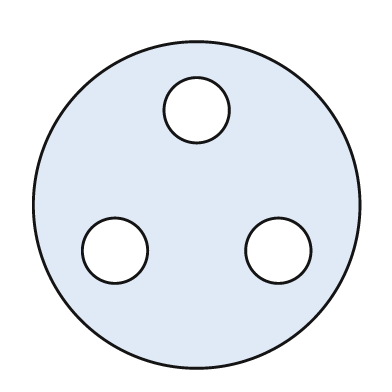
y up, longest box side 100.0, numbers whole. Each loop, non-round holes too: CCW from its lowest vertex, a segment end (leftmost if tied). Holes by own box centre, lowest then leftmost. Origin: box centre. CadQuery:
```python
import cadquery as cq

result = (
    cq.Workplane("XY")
    .moveTo(0.0, 0.0)
    .circle(50.0)
    .moveTo(-25.0, -14.0)
    .circle(10.0)
    .moveTo(25.0, -14.0)
    .circle(10.0)
    .moveTo(0.0, 29.0)
    .circle(10.0)
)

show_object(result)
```